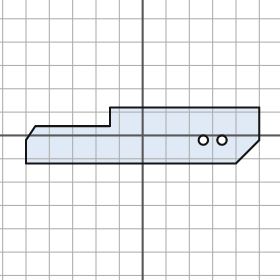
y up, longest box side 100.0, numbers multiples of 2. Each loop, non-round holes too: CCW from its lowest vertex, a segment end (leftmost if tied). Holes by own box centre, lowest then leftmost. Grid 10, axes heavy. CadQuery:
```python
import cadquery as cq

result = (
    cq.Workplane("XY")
    .moveTo(-50.0, -12.0)
    .lineTo(40.0, -12.0)
    .lineTo(50.0, -2.0)
    .lineTo(50.0, 12.0)
    .lineTo(-14.0, 12.0)
    .lineTo(-14.0, 4.0)
    .lineTo(-46.0, 4.0)
    .lineTo(-50.0, -2.0)
    .close()
    .moveTo(26.0, -2.0)
    .circle(2.0)
    .moveTo(34.0, -2.0)
    .circle(2.0)
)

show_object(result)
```